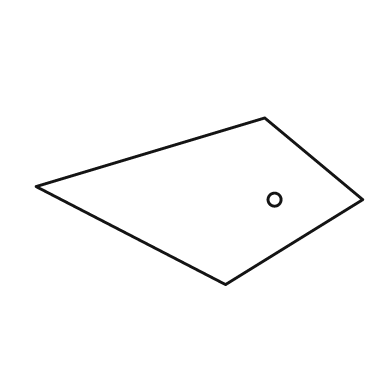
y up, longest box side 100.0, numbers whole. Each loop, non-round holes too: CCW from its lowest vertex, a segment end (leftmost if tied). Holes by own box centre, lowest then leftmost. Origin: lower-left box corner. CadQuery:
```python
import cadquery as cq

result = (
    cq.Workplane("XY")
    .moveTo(58.0, 0.0)
    .lineTo(100.0, 26.0)
    .lineTo(70.0, 51.0)
    .lineTo(0.0, 30.0)
    .close()
    .moveTo(73.0, 26.0)
    .circle(2.0)
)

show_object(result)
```